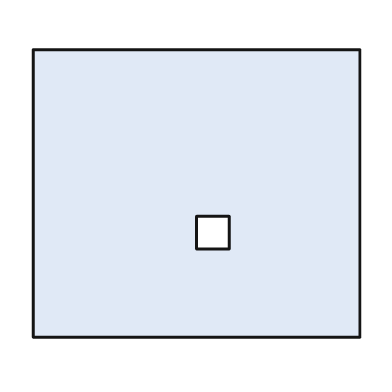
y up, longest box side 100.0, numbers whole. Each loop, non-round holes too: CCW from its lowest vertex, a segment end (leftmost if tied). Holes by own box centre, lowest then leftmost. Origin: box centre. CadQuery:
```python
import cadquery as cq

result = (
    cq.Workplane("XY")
    .moveTo(-50.0, -44.0)
    .lineTo(50.0, -44.0)
    .lineTo(50.0, 44.0)
    .lineTo(-50.0, 44.0)
    .close()
    .moveTo(0.0, -17.0)
    .lineTo(10.0, -17.0)
    .lineTo(10.0, -7.0)
    .lineTo(0.0, -7.0)
    .close()
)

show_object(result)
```